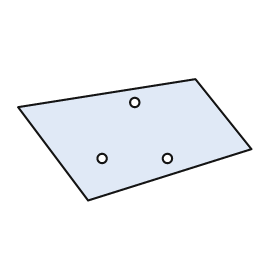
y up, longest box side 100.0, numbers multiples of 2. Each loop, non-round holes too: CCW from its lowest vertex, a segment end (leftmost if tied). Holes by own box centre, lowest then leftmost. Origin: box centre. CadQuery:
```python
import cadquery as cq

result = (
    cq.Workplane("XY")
    .moveTo(-20.0, -26.0)
    .lineTo(50.0, -4.0)
    .lineTo(26.0, 26.0)
    .lineTo(-50.0, 14.0)
    .close()
    .moveTo(-14.0, -8.0)
    .circle(2.0)
    .moveTo(14.0, -8.0)
    .circle(2.0)
    .moveTo(0.0, 16.0)
    .circle(2.0)
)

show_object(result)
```